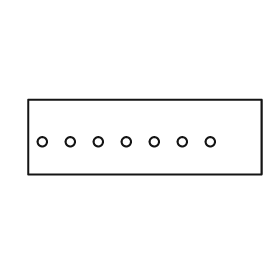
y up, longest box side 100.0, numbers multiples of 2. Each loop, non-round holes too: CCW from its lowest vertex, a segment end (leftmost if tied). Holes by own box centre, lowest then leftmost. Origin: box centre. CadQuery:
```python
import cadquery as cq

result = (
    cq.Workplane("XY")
    .moveTo(-50.0, -16.0)
    .lineTo(50.0, -16.0)
    .lineTo(50.0, 16.0)
    .lineTo(-50.0, 16.0)
    .close()
    .moveTo(-44.0, -2.0)
    .circle(2.0)
    .moveTo(-32.0, -2.0)
    .circle(2.0)
    .moveTo(-20.0, -2.0)
    .circle(2.0)
    .moveTo(-8.0, -2.0)
    .circle(2.0)
    .moveTo(4.0, -2.0)
    .circle(2.0)
    .moveTo(16.0, -2.0)
    .circle(2.0)
    .moveTo(28.0, -2.0)
    .circle(2.0)
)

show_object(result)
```